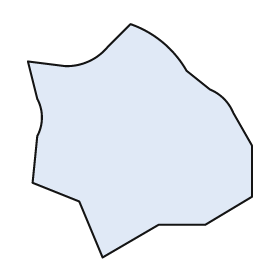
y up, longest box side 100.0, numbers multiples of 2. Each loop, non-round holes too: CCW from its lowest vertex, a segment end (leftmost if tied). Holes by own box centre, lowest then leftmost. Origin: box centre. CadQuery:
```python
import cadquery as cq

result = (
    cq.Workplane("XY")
    .moveTo(-16.0, -50.0)
    .lineTo(8.0, -36.0)
    .lineTo(28.0, -36.0)
    .lineTo(48.0, -24.0)
    .lineTo(48.0, -2.0)
    .lineTo(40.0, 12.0)
    .threePointArc((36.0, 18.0), (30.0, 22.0))
    .lineTo(20.0, 30.0)
    .threePointArc((10.0, 42.0), (-4.0, 50.0))
    .lineTo(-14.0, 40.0)
    .threePointArc((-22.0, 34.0), (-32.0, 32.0))
    .lineTo(-48.0, 34.0)
    .lineTo(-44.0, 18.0)
    .threePointArc((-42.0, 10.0), (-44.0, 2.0))
    .lineTo(-46.0, -18.0)
    .lineTo(-26.0, -26.0)
    .close()
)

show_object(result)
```